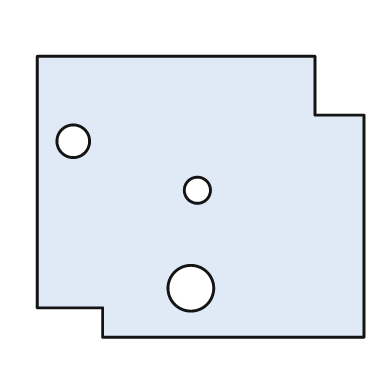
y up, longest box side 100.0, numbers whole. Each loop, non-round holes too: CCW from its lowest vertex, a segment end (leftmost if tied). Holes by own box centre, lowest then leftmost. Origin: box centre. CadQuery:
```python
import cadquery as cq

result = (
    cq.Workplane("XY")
    .moveTo(-30.0, -43.0)
    .lineTo(50.0, -43.0)
    .lineTo(50.0, 25.0)
    .lineTo(35.0, 25.0)
    .lineTo(35.0, 43.0)
    .lineTo(-50.0, 43.0)
    .lineTo(-50.0, -34.0)
    .lineTo(-30.0, -34.0)
    .close()
    .moveTo(-3.0, -28.0)
    .circle(7.0)
    .moveTo(-1.0, 2.0)
    .circle(4.0)
    .moveTo(-39.0, 17.0)
    .circle(5.0)
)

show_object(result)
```